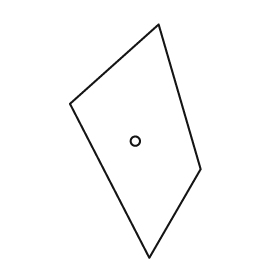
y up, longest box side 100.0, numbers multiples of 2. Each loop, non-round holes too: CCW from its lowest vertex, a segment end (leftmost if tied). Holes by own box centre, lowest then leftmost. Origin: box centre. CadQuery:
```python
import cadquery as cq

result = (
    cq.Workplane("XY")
    .moveTo(6.0, -50.0)
    .lineTo(28.0, -12.0)
    .lineTo(10.0, 50.0)
    .lineTo(-28.0, 16.0)
    .close()
    .moveTo(0.0, 0.0)
    .circle(2.0)
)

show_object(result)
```